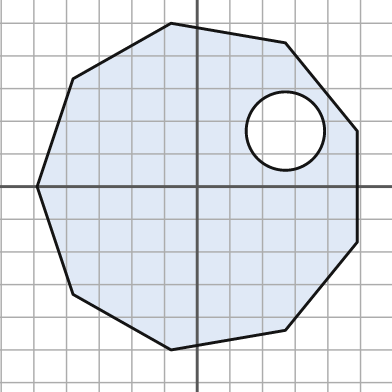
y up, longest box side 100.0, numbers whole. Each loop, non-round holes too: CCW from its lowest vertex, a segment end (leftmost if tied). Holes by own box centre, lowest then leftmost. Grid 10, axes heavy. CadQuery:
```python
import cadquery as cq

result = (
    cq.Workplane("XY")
    .moveTo(-8.0, -50.0)
    .lineTo(27.0, -44.0)
    .lineTo(49.0, -17.0)
    .lineTo(49.0, 17.0)
    .lineTo(27.0, 44.0)
    .lineTo(-8.0, 50.0)
    .lineTo(-38.0, 33.0)
    .lineTo(-49.0, 0.0)
    .lineTo(-38.0, -33.0)
    .close()
    .moveTo(27.0, 17.0)
    .circle(12.0)
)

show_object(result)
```